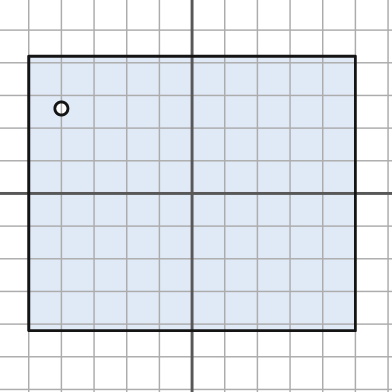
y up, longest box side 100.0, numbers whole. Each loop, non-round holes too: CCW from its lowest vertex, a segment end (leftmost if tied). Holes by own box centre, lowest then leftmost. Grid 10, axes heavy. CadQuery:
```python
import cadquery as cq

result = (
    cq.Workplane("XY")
    .moveTo(-50.0, -42.0)
    .lineTo(50.0, -42.0)
    .lineTo(50.0, 42.0)
    .lineTo(-50.0, 42.0)
    .close()
    .moveTo(-40.0, 26.0)
    .circle(2.0)
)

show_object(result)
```